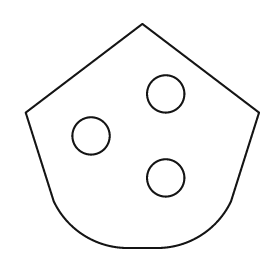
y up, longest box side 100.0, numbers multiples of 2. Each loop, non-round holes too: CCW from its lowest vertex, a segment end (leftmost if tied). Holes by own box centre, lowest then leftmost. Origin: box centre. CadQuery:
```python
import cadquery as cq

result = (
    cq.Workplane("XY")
    .moveTo(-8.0, -48.0)
    .lineTo(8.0, -48.0)
    .threePointArc((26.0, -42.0), (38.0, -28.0))
    .lineTo(50.0, 10.0)
    .lineTo(0.0, 48.0)
    .lineTo(-50.0, 10.0)
    .lineTo(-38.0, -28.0)
    .threePointArc((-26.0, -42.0), (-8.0, -48.0))
    .close()
    .moveTo(10.0, -18.0)
    .circle(8.0)
    .moveTo(-22.0, 0.0)
    .circle(8.0)
    .moveTo(10.0, 18.0)
    .circle(8.0)
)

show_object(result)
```